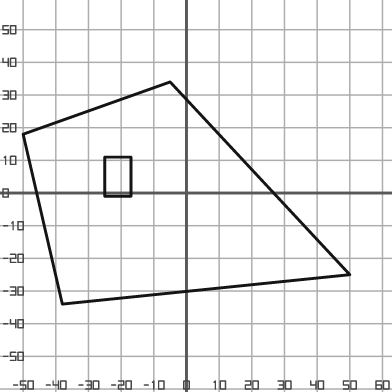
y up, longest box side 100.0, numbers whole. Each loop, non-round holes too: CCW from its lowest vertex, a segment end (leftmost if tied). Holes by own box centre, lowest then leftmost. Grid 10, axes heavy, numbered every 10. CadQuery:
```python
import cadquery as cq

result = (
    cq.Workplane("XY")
    .moveTo(-38.0, -34.0)
    .lineTo(50.0, -25.0)
    .lineTo(-5.0, 34.0)
    .lineTo(-50.0, 18.0)
    .close()
    .moveTo(-25.0, -1.0)
    .lineTo(-17.0, -1.0)
    .lineTo(-17.0, 11.0)
    .lineTo(-25.0, 11.0)
    .close()
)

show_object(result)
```